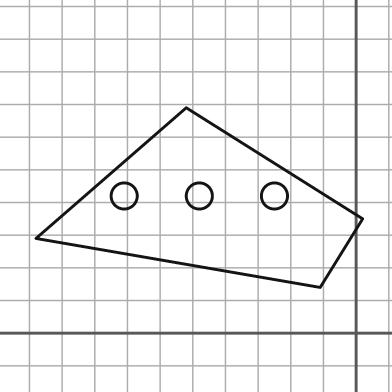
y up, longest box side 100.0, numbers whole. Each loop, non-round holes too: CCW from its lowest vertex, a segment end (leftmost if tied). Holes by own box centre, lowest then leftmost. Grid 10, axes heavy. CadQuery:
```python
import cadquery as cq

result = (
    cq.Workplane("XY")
    .moveTo(-11.0, 14.0)
    .lineTo(2.0, 35.0)
    .lineTo(-52.0, 69.0)
    .lineTo(-98.0, 29.0)
    .close()
    .moveTo(-71.0, 42.0)
    .circle(4.0)
    .moveTo(-48.0, 42.0)
    .circle(4.0)
    .moveTo(-25.0, 42.0)
    .circle(4.0)
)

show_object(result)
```